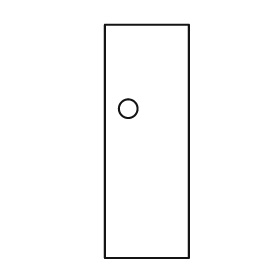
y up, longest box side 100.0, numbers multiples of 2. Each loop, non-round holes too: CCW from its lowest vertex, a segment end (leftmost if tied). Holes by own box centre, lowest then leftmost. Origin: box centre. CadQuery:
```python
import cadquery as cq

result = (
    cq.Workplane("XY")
    .moveTo(-18.0, -50.0)
    .lineTo(18.0, -50.0)
    .lineTo(18.0, 50.0)
    .lineTo(-18.0, 50.0)
    .close()
    .moveTo(-8.0, 14.0)
    .circle(4.0)
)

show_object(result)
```